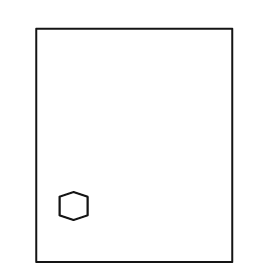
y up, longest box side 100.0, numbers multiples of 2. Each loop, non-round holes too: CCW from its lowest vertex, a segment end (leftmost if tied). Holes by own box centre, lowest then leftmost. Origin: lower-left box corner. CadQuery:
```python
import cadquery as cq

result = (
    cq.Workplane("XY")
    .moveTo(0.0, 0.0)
    .lineTo(84.0, 0.0)
    .lineTo(84.0, 100.0)
    .lineTo(0.0, 100.0)
    .close()
    .moveTo(16.0, 18.0)
    .lineTo(22.0, 20.0)
    .lineTo(22.0, 28.0)
    .lineTo(16.0, 30.0)
    .lineTo(10.0, 28.0)
    .lineTo(10.0, 20.0)
    .close()
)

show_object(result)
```